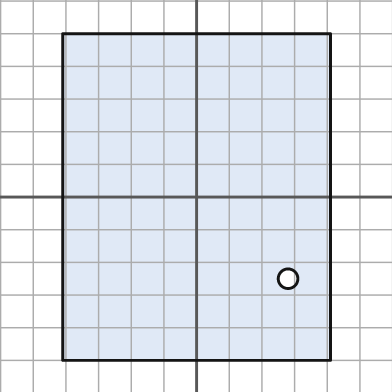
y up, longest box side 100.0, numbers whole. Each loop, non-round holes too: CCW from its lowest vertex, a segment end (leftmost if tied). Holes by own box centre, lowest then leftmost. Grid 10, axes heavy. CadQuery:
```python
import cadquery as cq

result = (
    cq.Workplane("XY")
    .moveTo(-41.0, -50.0)
    .lineTo(41.0, -50.0)
    .lineTo(41.0, 50.0)
    .lineTo(-41.0, 50.0)
    .close()
    .moveTo(28.0, -25.0)
    .circle(3.0)
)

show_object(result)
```